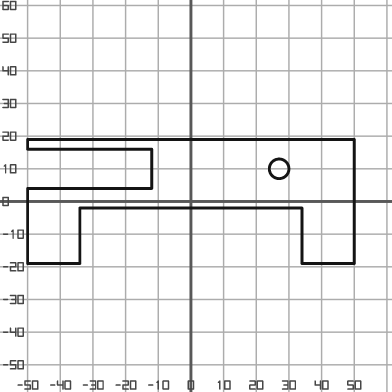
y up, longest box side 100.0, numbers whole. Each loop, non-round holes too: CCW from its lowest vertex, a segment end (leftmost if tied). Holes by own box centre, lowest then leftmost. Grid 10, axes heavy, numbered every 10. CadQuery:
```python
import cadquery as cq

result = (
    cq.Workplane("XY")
    .moveTo(-50.0, -19.0)
    .lineTo(-34.0, -19.0)
    .lineTo(-34.0, -2.0)
    .lineTo(34.0, -2.0)
    .lineTo(34.0, -19.0)
    .lineTo(50.0, -19.0)
    .lineTo(50.0, 19.0)
    .lineTo(-50.0, 19.0)
    .lineTo(-50.0, 16.0)
    .lineTo(-12.0, 16.0)
    .lineTo(-12.0, 4.0)
    .lineTo(-50.0, 4.0)
    .close()
    .moveTo(27.0, 10.0)
    .circle(3.0)
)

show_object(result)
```